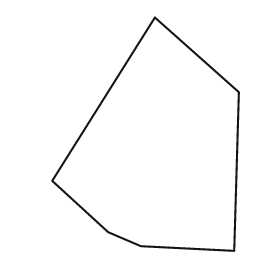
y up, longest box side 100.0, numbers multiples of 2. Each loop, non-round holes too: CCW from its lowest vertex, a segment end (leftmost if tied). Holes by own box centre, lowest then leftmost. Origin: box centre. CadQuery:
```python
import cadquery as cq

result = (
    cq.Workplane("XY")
    .moveTo(38.0, -50.0)
    .lineTo(40.0, 18.0)
    .lineTo(4.0, 50.0)
    .lineTo(-40.0, -20.0)
    .lineTo(-16.0, -42.0)
    .lineTo(-2.0, -48.0)
    .close()
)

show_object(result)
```